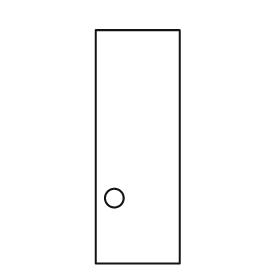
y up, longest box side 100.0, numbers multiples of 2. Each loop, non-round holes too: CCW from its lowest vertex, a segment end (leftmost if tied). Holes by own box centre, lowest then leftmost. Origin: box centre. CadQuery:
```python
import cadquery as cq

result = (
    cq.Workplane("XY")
    .moveTo(-18.0, -50.0)
    .lineTo(18.0, -50.0)
    .lineTo(18.0, 50.0)
    .lineTo(-18.0, 50.0)
    .close()
    .moveTo(-10.0, -22.0)
    .circle(4.0)
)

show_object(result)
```